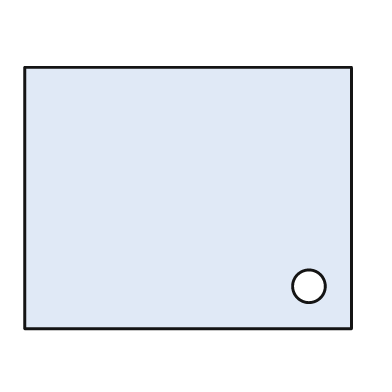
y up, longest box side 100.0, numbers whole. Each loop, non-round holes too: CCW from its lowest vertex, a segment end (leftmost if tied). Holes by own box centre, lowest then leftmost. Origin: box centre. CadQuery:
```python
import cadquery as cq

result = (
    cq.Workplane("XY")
    .moveTo(-50.0, -40.0)
    .lineTo(50.0, -40.0)
    .lineTo(50.0, 40.0)
    .lineTo(-50.0, 40.0)
    .close()
    .moveTo(37.0, -27.0)
    .circle(5.0)
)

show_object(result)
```